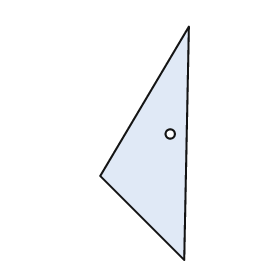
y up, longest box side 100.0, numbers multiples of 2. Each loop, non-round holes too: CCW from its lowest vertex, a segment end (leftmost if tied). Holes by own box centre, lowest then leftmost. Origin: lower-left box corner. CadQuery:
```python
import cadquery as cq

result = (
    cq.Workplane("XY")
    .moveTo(36.0, 0.0)
    .lineTo(38.0, 100.0)
    .lineTo(0.0, 36.0)
    .close()
    .moveTo(30.0, 54.0)
    .circle(2.0)
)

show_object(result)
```